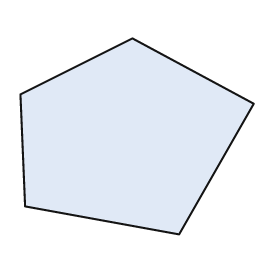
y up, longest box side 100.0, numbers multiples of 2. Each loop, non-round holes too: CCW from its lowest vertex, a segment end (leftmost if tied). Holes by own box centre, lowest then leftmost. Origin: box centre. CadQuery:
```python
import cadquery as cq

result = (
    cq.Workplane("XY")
    .moveTo(18.0, -42.0)
    .lineTo(50.0, 14.0)
    .lineTo(-2.0, 42.0)
    .lineTo(-50.0, 18.0)
    .lineTo(-48.0, -30.0)
    .close()
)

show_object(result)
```